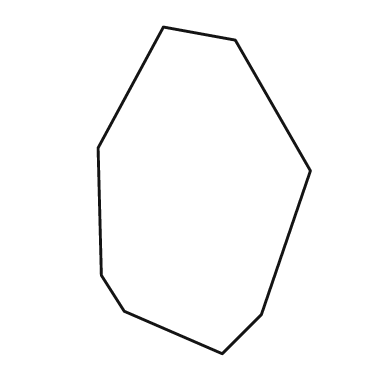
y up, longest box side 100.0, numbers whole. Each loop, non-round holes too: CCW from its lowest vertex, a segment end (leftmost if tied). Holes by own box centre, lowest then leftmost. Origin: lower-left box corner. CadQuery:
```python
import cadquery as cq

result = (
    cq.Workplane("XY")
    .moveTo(38.0, 0.0)
    .lineTo(50.0, 12.0)
    .lineTo(65.0, 56.0)
    .lineTo(42.0, 96.0)
    .lineTo(20.0, 100.0)
    .lineTo(0.0, 63.0)
    .lineTo(1.0, 24.0)
    .lineTo(8.0, 13.0)
    .close()
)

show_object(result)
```